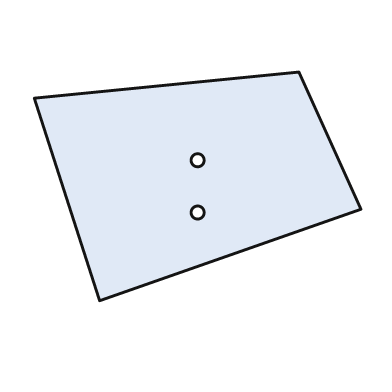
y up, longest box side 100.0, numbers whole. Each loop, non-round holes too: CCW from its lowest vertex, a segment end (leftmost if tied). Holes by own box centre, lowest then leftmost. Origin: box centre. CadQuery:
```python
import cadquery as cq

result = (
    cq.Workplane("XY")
    .moveTo(-30.0, -35.0)
    .lineTo(50.0, -7.0)
    .lineTo(31.0, 35.0)
    .lineTo(-50.0, 27.0)
    .close()
    .moveTo(0.0, -8.0)
    .circle(2.0)
    .moveTo(0.0, 8.0)
    .circle(2.0)
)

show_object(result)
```